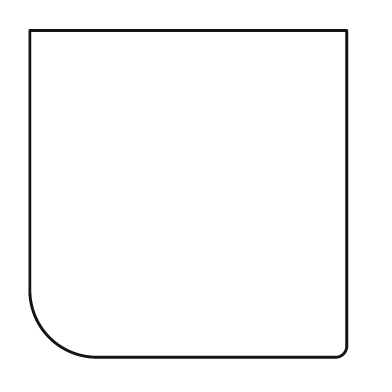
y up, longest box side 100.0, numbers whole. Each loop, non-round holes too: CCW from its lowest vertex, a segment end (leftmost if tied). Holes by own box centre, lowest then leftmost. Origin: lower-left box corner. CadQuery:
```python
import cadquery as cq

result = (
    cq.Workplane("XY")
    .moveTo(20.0, 0.0)
    .lineTo(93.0, 0.0)
    .threePointArc((96.0, 1.0), (97.0, 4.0))
    .lineTo(97.0, 100.0)
    .lineTo(0.0, 100.0)
    .lineTo(0.0, 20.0)
    .threePointArc((6.0, 6.0), (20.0, 0.0))
    .close()
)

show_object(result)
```